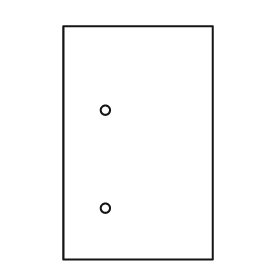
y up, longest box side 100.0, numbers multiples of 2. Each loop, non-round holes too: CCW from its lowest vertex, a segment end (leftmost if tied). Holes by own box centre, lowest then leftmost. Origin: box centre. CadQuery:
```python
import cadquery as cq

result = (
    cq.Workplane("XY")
    .moveTo(-32.0, -50.0)
    .lineTo(32.0, -50.0)
    .lineTo(32.0, 50.0)
    .lineTo(-32.0, 50.0)
    .close()
    .moveTo(-14.0, -28.0)
    .circle(2.0)
    .moveTo(-14.0, 14.0)
    .circle(2.0)
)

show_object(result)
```